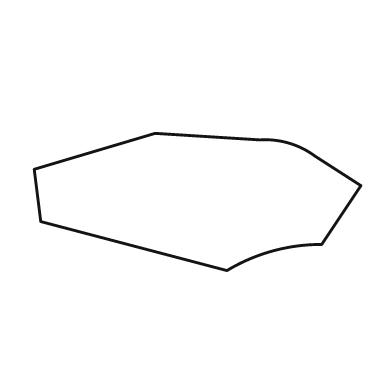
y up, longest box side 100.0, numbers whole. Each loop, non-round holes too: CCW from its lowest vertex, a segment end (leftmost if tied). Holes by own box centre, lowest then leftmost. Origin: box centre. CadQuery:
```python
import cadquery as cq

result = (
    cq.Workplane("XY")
    .moveTo(9.0, -21.0)
    .threePointArc((23.0, -15.0), (38.0, -13.0))
    .lineTo(50.0, 5.0)
    .lineTo(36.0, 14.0)
    .threePointArc((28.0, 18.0), (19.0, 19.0))
    .lineTo(-13.0, 21.0)
    .lineTo(-50.0, 10.0)
    .lineTo(-48.0, -6.0)
    .close()
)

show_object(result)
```